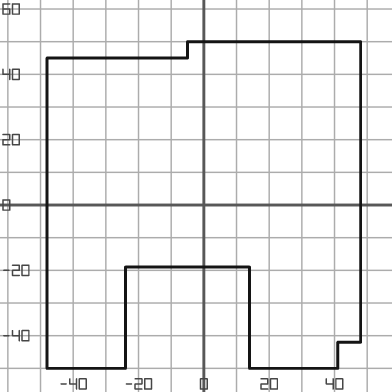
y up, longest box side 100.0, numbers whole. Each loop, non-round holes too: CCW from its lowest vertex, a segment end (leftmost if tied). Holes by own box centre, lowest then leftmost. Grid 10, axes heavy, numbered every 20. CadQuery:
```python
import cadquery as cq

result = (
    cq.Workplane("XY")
    .moveTo(-48.0, -50.0)
    .lineTo(-24.0, -50.0)
    .lineTo(-24.0, -19.0)
    .lineTo(14.0, -19.0)
    .lineTo(14.0, -50.0)
    .lineTo(41.0, -50.0)
    .lineTo(41.0, -42.0)
    .lineTo(48.0, -42.0)
    .lineTo(48.0, 50.0)
    .lineTo(-5.0, 50.0)
    .lineTo(-5.0, 45.0)
    .lineTo(-48.0, 45.0)
    .close()
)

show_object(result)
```